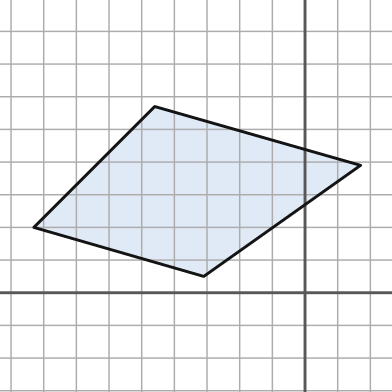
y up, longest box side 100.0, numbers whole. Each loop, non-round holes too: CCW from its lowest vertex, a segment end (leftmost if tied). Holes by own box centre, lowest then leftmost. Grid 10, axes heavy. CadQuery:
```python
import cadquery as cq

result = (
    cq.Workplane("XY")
    .moveTo(-31.0, 5.0)
    .lineTo(17.0, 39.0)
    .lineTo(-46.0, 57.0)
    .lineTo(-83.0, 20.0)
    .close()
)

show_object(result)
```